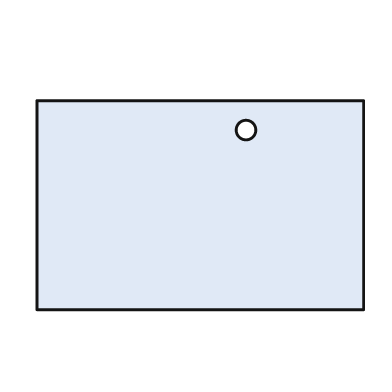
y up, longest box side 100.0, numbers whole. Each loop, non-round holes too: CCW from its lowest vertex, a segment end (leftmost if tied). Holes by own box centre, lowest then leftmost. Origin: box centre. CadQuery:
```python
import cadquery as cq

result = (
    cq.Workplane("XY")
    .moveTo(-50.0, -32.0)
    .lineTo(50.0, -32.0)
    .lineTo(50.0, 32.0)
    .lineTo(-50.0, 32.0)
    .close()
    .moveTo(14.0, 23.0)
    .circle(3.0)
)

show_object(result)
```